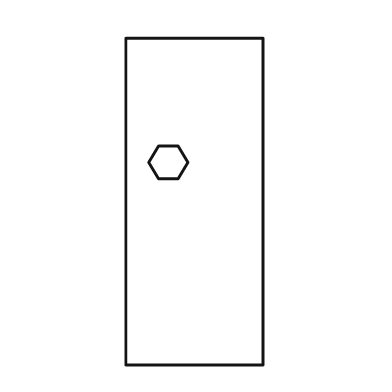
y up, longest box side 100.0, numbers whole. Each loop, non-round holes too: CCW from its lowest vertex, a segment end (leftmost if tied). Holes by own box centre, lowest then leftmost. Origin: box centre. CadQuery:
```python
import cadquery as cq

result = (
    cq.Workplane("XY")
    .moveTo(-21.0, -50.0)
    .lineTo(21.0, -50.0)
    .lineTo(21.0, 50.0)
    .lineTo(-21.0, 50.0)
    .close()
    .moveTo(-11.0, 7.0)
    .lineTo(-5.0, 7.0)
    .lineTo(-2.0, 12.0)
    .lineTo(-5.0, 17.0)
    .lineTo(-11.0, 17.0)
    .lineTo(-14.0, 12.0)
    .close()
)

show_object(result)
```